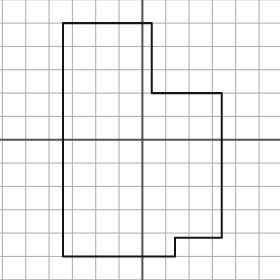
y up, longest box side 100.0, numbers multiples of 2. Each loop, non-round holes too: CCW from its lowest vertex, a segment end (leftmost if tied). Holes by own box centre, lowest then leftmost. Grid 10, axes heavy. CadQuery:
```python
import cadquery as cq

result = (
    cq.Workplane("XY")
    .moveTo(-34.0, -50.0)
    .lineTo(14.0, -50.0)
    .lineTo(14.0, -42.0)
    .lineTo(34.0, -42.0)
    .lineTo(34.0, 20.0)
    .lineTo(4.0, 20.0)
    .lineTo(4.0, 50.0)
    .lineTo(-34.0, 50.0)
    .close()
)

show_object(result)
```